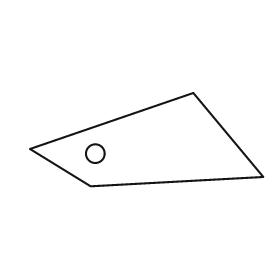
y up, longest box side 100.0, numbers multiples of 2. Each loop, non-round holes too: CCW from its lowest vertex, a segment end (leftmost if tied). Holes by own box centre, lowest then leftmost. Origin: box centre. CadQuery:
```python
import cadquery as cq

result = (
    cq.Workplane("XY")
    .moveTo(-24.0, -20.0)
    .lineTo(50.0, -16.0)
    .lineTo(20.0, 20.0)
    .lineTo(-50.0, -4.0)
    .close()
    .moveTo(-22.0, -6.0)
    .circle(4.0)
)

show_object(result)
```